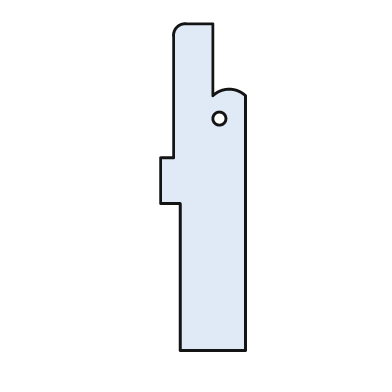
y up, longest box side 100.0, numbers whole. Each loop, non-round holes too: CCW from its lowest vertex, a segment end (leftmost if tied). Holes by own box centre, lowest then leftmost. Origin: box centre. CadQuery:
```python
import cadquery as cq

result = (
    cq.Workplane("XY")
    .moveTo(-7.0, -50.0)
    .lineTo(13.0, -50.0)
    .lineTo(13.0, 28.0)
    .threePointArc((8.0, 30.0), (3.0, 28.0))
    .lineTo(3.0, 50.0)
    .lineTo(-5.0, 50.0)
    .threePointArc((-8.0, 49.0), (-9.0, 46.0))
    .lineTo(-9.0, 9.0)
    .lineTo(-13.0, 9.0)
    .lineTo(-13.0, -5.0)
    .lineTo(-7.0, -5.0)
    .close()
    .moveTo(5.0, 21.0)
    .circle(2.0)
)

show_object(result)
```